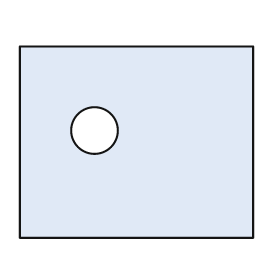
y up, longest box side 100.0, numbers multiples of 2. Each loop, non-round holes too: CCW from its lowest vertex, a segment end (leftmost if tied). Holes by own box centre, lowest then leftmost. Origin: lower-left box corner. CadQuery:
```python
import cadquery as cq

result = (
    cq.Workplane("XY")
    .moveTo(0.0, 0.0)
    .lineTo(100.0, 0.0)
    .lineTo(100.0, 82.0)
    .lineTo(0.0, 82.0)
    .close()
    .moveTo(32.0, 46.0)
    .circle(10.0)
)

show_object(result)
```